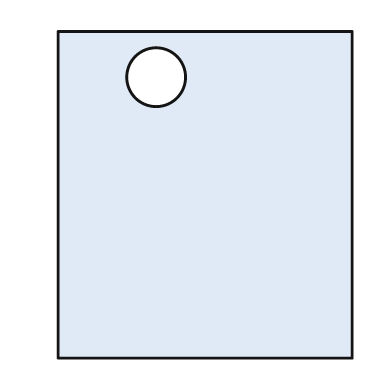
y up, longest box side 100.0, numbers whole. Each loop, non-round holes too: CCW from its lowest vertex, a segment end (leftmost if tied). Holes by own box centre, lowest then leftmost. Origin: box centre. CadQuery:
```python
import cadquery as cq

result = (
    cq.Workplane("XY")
    .moveTo(-45.0, -50.0)
    .lineTo(45.0, -50.0)
    .lineTo(45.0, 50.0)
    .lineTo(-45.0, 50.0)
    .close()
    .moveTo(-15.0, 36.0)
    .circle(9.0)
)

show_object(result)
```